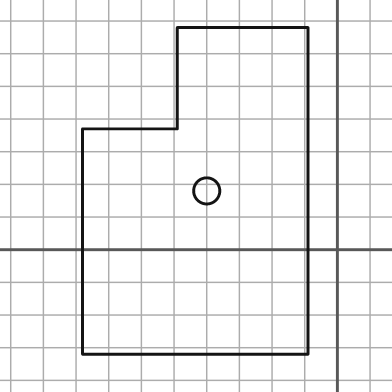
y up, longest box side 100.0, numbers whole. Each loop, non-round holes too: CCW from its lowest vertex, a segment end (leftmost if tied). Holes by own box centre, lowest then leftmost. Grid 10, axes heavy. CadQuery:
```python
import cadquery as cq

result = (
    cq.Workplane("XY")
    .moveTo(-78.0, -32.0)
    .lineTo(-9.0, -32.0)
    .lineTo(-9.0, 68.0)
    .lineTo(-49.0, 68.0)
    .lineTo(-49.0, 37.0)
    .lineTo(-78.0, 37.0)
    .close()
    .moveTo(-40.0, 18.0)
    .circle(4.0)
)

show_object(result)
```